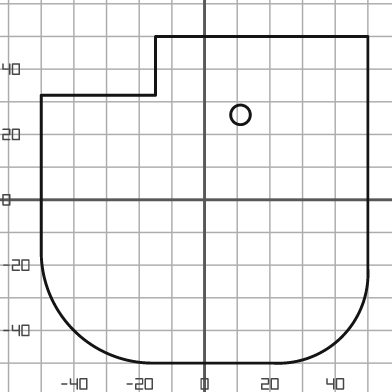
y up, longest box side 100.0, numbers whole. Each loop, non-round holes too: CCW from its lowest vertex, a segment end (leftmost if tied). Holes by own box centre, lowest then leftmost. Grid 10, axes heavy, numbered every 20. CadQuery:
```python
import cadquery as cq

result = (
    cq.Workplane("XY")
    .moveTo(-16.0, -50.0)
    .lineTo(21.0, -50.0)
    .threePointArc((42.0, -42.0), (50.0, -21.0))
    .lineTo(50.0, 50.0)
    .lineTo(-15.0, 50.0)
    .lineTo(-15.0, 32.0)
    .lineTo(-50.0, 32.0)
    .lineTo(-50.0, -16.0)
    .threePointArc((-40.0, -40.0), (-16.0, -50.0))
    .close()
    .moveTo(11.0, 26.0)
    .circle(3.0)
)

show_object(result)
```